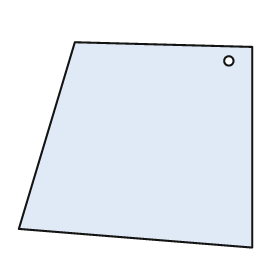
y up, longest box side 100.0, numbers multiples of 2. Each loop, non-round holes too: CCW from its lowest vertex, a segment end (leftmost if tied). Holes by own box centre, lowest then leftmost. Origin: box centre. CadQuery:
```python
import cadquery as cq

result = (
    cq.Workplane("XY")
    .moveTo(50.0, -44.0)
    .lineTo(50.0, 42.0)
    .lineTo(-26.0, 44.0)
    .lineTo(-50.0, -36.0)
    .close()
    .moveTo(40.0, 36.0)
    .circle(2.0)
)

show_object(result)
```